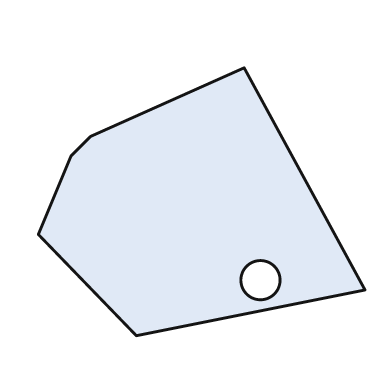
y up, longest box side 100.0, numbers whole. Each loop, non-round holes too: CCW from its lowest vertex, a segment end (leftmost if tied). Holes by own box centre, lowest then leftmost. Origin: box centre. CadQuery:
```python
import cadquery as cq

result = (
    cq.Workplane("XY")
    .moveTo(-20.0, -41.0)
    .lineTo(50.0, -27.0)
    .lineTo(13.0, 41.0)
    .lineTo(-34.0, 20.0)
    .lineTo(-40.0, 14.0)
    .lineTo(-50.0, -10.0)
    .close()
    .moveTo(18.0, -24.0)
    .circle(6.0)
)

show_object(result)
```